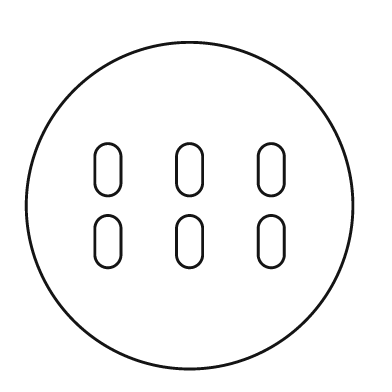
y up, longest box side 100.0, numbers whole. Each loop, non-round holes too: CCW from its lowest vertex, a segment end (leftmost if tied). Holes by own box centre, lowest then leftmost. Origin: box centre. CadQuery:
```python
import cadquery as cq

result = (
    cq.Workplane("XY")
    .moveTo(0.0, 0.0)
    .circle(50.0)
    .moveTo(-29.0, -15.0)
    .threePointArc((-25.0, -19.0), (-21.0, -15.0))
    .lineTo(-21.0, -7.0)
    .threePointArc((-25.0, -3.0), (-29.0, -7.0))
    .close()
    .moveTo(-4.0, -15.0)
    .threePointArc((0.0, -19.0), (4.0, -15.0))
    .lineTo(4.0, -7.0)
    .threePointArc((0.0, -3.0), (-4.0, -7.0))
    .close()
    .moveTo(21.0, -15.0)
    .threePointArc((25.0, -19.0), (29.0, -15.0))
    .lineTo(29.0, -7.0)
    .threePointArc((25.0, -3.0), (21.0, -7.0))
    .close()
    .moveTo(-29.0, 7.0)
    .threePointArc((-25.0, 3.0), (-21.0, 7.0))
    .lineTo(-21.0, 15.0)
    .threePointArc((-25.0, 19.0), (-29.0, 15.0))
    .close()
    .moveTo(-4.0, 7.0)
    .threePointArc((0.0, 3.0), (4.0, 7.0))
    .lineTo(4.0, 15.0)
    .threePointArc((0.0, 19.0), (-4.0, 15.0))
    .close()
    .moveTo(21.0, 7.0)
    .threePointArc((25.0, 3.0), (29.0, 7.0))
    .lineTo(29.0, 15.0)
    .threePointArc((25.0, 19.0), (21.0, 15.0))
    .close()
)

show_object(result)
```